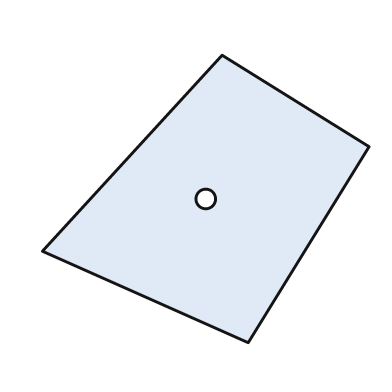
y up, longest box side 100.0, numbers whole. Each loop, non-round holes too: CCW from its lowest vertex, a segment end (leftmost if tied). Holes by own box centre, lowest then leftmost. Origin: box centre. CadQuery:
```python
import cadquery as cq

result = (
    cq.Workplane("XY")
    .moveTo(13.0, -44.0)
    .lineTo(50.0, 16.0)
    .lineTo(5.0, 44.0)
    .lineTo(-50.0, -16.0)
    .close()
    .moveTo(0.0, 0.0)
    .circle(3.0)
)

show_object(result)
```